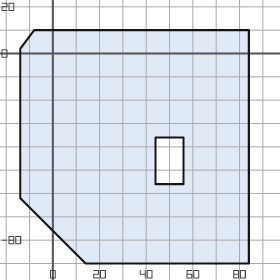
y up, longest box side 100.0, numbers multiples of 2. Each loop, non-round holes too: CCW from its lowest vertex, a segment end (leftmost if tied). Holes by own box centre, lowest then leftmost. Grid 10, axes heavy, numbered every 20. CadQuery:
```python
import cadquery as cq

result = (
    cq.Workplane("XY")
    .moveTo(14.0, -90.0)
    .lineTo(84.0, -90.0)
    .lineTo(84.0, 10.0)
    .lineTo(-8.0, 10.0)
    .lineTo(-14.0, 2.0)
    .lineTo(-14.0, -62.0)
    .close()
    .moveTo(44.0, -56.0)
    .lineTo(56.0, -56.0)
    .lineTo(56.0, -36.0)
    .lineTo(44.0, -36.0)
    .close()
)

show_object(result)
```